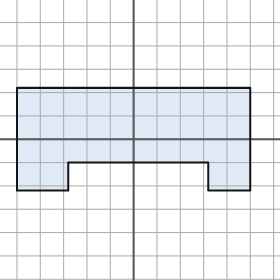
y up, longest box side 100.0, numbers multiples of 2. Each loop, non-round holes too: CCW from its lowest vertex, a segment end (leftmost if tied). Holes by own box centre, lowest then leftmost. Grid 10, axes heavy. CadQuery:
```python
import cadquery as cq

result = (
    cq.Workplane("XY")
    .moveTo(-50.0, -22.0)
    .lineTo(-28.0, -22.0)
    .lineTo(-28.0, -10.0)
    .lineTo(32.0, -10.0)
    .lineTo(32.0, -22.0)
    .lineTo(50.0, -22.0)
    .lineTo(50.0, 22.0)
    .lineTo(-50.0, 22.0)
    .close()
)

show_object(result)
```